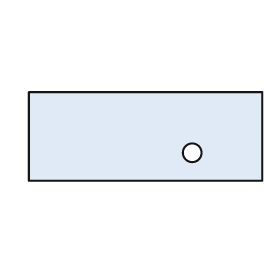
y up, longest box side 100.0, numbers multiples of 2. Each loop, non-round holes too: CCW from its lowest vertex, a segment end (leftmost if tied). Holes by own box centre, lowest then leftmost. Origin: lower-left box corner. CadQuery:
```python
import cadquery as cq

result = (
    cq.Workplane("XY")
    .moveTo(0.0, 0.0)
    .lineTo(100.0, 0.0)
    .lineTo(100.0, 38.0)
    .lineTo(0.0, 38.0)
    .close()
    .moveTo(70.0, 12.0)
    .circle(4.0)
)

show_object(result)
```